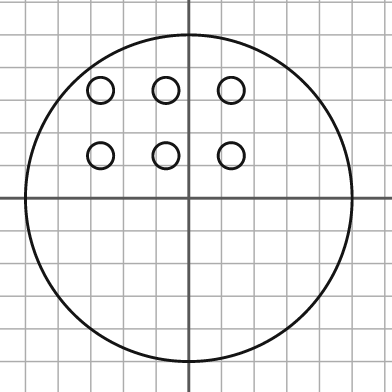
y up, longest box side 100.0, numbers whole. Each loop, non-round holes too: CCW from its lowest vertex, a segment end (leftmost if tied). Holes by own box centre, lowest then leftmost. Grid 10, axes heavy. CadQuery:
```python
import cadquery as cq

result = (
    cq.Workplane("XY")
    .moveTo(0.0, 0.0)
    .circle(50.0)
    .moveTo(-27.0, 13.0)
    .circle(4.0)
    .moveTo(-7.0, 13.0)
    .circle(4.0)
    .moveTo(13.0, 13.0)
    .circle(4.0)
    .moveTo(-27.0, 33.0)
    .circle(4.0)
    .moveTo(-7.0, 33.0)
    .circle(4.0)
    .moveTo(13.0, 33.0)
    .circle(4.0)
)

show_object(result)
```